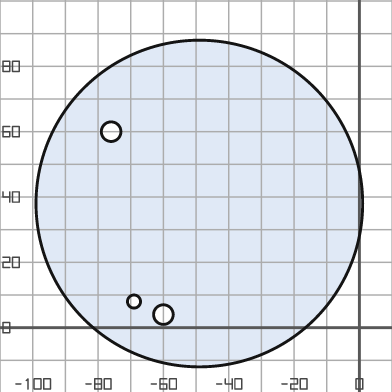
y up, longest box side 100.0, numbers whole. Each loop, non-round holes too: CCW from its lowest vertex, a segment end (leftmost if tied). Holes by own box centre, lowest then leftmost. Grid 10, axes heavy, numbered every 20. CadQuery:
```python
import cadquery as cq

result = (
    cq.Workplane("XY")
    .moveTo(-49.0, 38.0)
    .circle(50.0)
    .moveTo(-60.0, 4.0)
    .circle(3.0)
    .moveTo(-69.0, 8.0)
    .circle(2.0)
    .moveTo(-76.0, 60.0)
    .circle(3.0)
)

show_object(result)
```